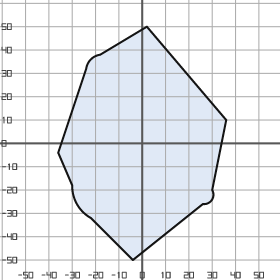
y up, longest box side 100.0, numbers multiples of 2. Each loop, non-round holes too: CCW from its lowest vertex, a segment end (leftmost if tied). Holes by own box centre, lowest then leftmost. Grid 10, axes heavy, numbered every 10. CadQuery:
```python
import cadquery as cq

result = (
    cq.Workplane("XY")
    .moveTo(-4.0, -50.0)
    .lineTo(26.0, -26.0)
    .threePointArc((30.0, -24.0), (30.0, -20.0))
    .lineTo(36.0, 10.0)
    .lineTo(2.0, 50.0)
    .lineTo(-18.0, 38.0)
    .threePointArc((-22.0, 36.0), (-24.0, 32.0))
    .lineTo(-36.0, -4.0)
    .lineTo(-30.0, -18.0)
    .threePointArc((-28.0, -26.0), (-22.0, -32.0))
    .close()
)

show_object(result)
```